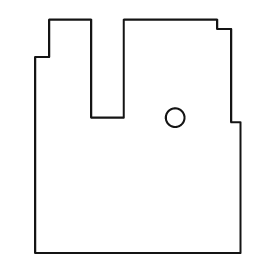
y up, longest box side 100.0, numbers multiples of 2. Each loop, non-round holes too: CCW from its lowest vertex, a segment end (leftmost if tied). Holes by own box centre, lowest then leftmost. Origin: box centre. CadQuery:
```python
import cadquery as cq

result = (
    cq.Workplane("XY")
    .moveTo(-44.0, -50.0)
    .lineTo(44.0, -50.0)
    .lineTo(44.0, 6.0)
    .lineTo(40.0, 6.0)
    .lineTo(40.0, 46.0)
    .lineTo(34.0, 46.0)
    .lineTo(34.0, 50.0)
    .lineTo(-6.0, 50.0)
    .lineTo(-6.0, 8.0)
    .lineTo(-20.0, 8.0)
    .lineTo(-20.0, 50.0)
    .lineTo(-38.0, 50.0)
    .lineTo(-38.0, 34.0)
    .lineTo(-44.0, 34.0)
    .close()
    .moveTo(16.0, 8.0)
    .circle(4.0)
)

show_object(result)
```